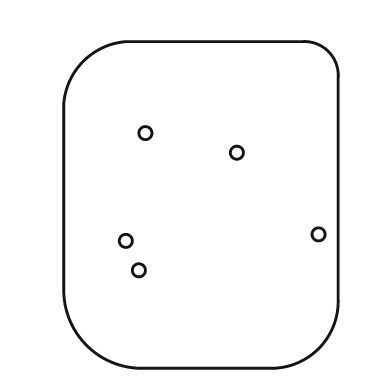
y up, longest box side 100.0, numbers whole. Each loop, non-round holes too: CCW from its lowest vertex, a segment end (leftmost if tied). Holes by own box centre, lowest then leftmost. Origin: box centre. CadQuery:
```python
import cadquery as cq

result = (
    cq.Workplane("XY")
    .moveTo(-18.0, -50.0)
    .lineTo(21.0, -50.0)
    .threePointArc((36.0, -44.0), (42.0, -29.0))
    .lineTo(42.0, 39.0)
    .threePointArc((39.0, 47.0), (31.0, 50.0))
    .lineTo(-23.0, 50.0)
    .threePointArc((-36.0, 44.0), (-42.0, 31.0))
    .lineTo(-42.0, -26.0)
    .threePointArc((-35.0, -43.0), (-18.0, -50.0))
    .close()
    .moveTo(-19.0, -20.0)
    .circle(2.0)
    .moveTo(-23.0, -11.0)
    .circle(2.0)
    .moveTo(36.0, -9.0)
    .circle(2.0)
    .moveTo(11.0, 16.0)
    .circle(2.0)
    .moveTo(-17.0, 22.0)
    .circle(2.0)
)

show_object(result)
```